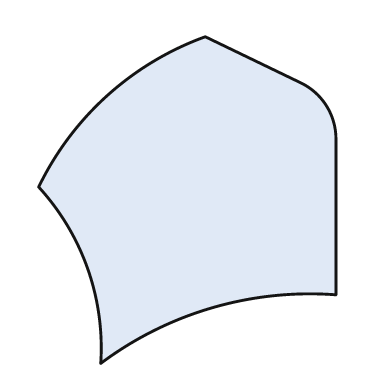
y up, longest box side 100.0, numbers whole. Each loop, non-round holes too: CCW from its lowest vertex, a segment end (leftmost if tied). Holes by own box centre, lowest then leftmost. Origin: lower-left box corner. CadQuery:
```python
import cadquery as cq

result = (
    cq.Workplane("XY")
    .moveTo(19.0, 0.0)
    .threePointArc((53.0, 17.0), (91.0, 21.0))
    .lineTo(91.0, 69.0)
    .threePointArc((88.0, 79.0), (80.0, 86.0))
    .lineTo(51.0, 100.0)
    .threePointArc((21.0, 82.0), (0.0, 54.0))
    .threePointArc((15.0, 29.0), (19.0, 0.0))
    .close()
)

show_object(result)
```